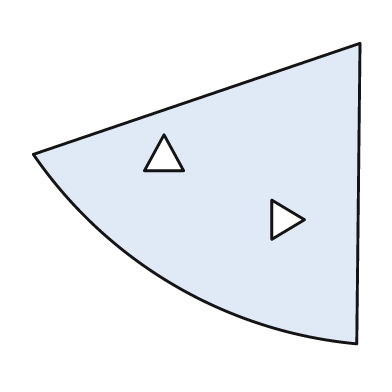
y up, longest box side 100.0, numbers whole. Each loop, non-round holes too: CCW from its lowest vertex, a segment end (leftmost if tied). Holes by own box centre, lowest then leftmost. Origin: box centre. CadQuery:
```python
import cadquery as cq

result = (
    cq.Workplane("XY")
    .moveTo(49.0, -46.0)
    .lineTo(50.0, 46.0)
    .lineTo(-50.0, 12.0)
    .threePointArc((-7.0, -28.0), (49.0, -46.0))
    .close()
    .moveTo(23.0, -14.0)
    .lineTo(33.0, -8.0)
    .lineTo(23.0, -2.0)
    .close()
    .moveTo(-16.0, 7.0)
    .lineTo(-4.0, 7.0)
    .lineTo(-10.0, 18.0)
    .close()
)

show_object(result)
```